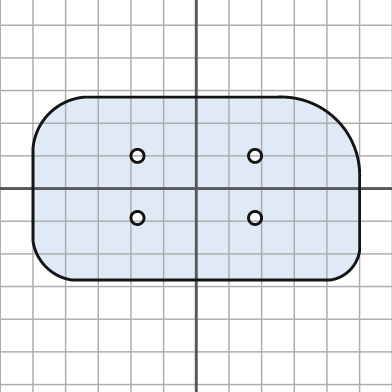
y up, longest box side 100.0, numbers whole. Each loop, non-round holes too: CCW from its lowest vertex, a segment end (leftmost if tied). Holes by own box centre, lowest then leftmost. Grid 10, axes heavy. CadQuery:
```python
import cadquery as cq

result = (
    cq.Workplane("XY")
    .moveTo(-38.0, -28.0)
    .lineTo(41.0, -28.0)
    .threePointArc((47.0, -25.0), (50.0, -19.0))
    .lineTo(50.0, 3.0)
    .threePointArc((43.0, 21.0), (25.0, 28.0))
    .lineTo(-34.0, 28.0)
    .threePointArc((-45.0, 23.0), (-50.0, 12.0))
    .lineTo(-50.0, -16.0)
    .threePointArc((-46.0, -24.0), (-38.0, -28.0))
    .close()
    .moveTo(-18.0, -9.0)
    .circle(2.0)
    .moveTo(18.0, -9.0)
    .circle(2.0)
    .moveTo(-18.0, 10.0)
    .circle(2.0)
    .moveTo(18.0, 10.0)
    .circle(2.0)
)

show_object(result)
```